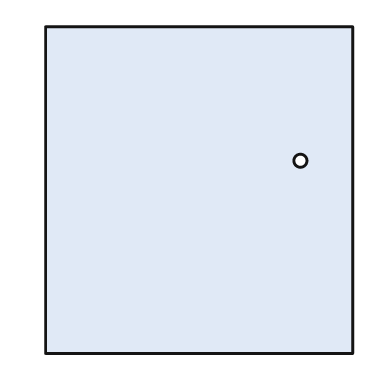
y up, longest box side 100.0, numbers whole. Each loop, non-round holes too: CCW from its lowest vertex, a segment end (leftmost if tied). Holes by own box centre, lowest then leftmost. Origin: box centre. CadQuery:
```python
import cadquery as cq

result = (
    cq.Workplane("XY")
    .moveTo(-47.0, -50.0)
    .lineTo(47.0, -50.0)
    .lineTo(47.0, 50.0)
    .lineTo(-47.0, 50.0)
    .close()
    .moveTo(31.0, 9.0)
    .circle(2.0)
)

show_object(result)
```